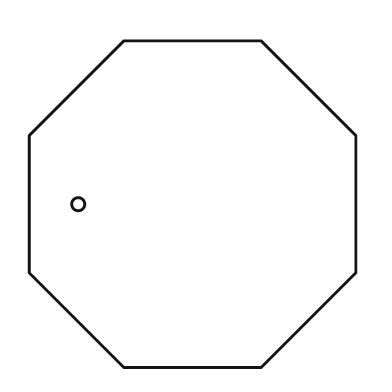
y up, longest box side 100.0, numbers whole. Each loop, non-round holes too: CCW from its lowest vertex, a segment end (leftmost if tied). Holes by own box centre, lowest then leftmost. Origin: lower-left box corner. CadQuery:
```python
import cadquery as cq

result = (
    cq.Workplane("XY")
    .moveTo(29.0, 0.0)
    .lineTo(71.0, 0.0)
    .lineTo(100.0, 29.0)
    .lineTo(100.0, 71.0)
    .lineTo(71.0, 100.0)
    .lineTo(29.0, 100.0)
    .lineTo(0.0, 71.0)
    .lineTo(0.0, 29.0)
    .close()
    .moveTo(15.0, 50.0)
    .circle(2.0)
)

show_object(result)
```